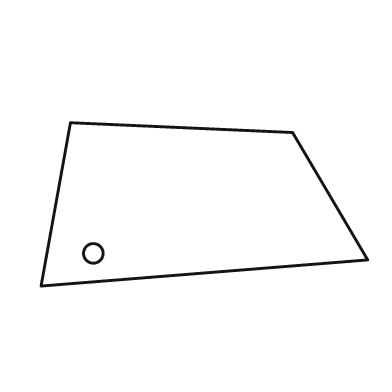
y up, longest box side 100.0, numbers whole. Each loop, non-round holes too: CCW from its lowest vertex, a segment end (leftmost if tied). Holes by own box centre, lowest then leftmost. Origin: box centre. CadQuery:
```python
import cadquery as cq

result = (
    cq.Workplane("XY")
    .moveTo(-50.0, -25.0)
    .lineTo(50.0, -17.0)
    .lineTo(27.0, 22.0)
    .lineTo(-41.0, 25.0)
    .close()
    .moveTo(-34.0, -15.0)
    .circle(3.0)
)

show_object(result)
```